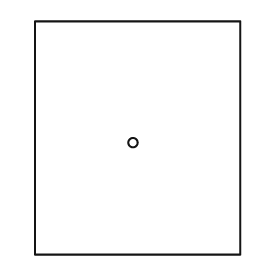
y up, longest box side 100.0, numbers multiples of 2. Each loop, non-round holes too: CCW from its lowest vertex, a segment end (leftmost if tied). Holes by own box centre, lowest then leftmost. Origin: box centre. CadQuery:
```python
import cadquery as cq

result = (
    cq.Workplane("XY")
    .moveTo(-44.0, -50.0)
    .lineTo(44.0, -50.0)
    .lineTo(44.0, 50.0)
    .lineTo(-44.0, 50.0)
    .close()
    .moveTo(-2.0, -2.0)
    .circle(2.0)
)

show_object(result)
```